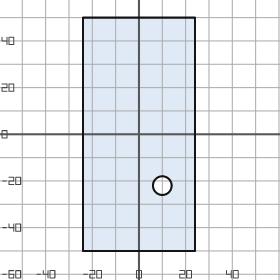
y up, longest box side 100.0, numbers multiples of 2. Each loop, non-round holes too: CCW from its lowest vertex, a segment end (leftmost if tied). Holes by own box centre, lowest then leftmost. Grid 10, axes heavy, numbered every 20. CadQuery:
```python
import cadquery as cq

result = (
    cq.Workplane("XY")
    .moveTo(-24.0, -50.0)
    .lineTo(24.0, -50.0)
    .lineTo(24.0, 50.0)
    .lineTo(-24.0, 50.0)
    .close()
    .moveTo(10.0, -22.0)
    .circle(4.0)
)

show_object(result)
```